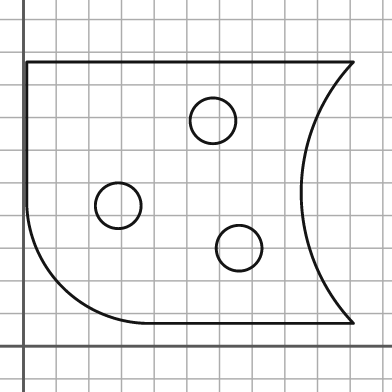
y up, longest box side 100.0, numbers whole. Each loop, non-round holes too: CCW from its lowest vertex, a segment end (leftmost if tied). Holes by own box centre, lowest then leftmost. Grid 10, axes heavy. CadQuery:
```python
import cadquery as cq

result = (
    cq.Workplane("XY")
    .moveTo(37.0, 7.0)
    .lineTo(101.0, 7.0)
    .threePointArc((85.0, 47.0), (101.0, 87.0))
    .lineTo(1.0, 87.0)
    .lineTo(1.0, 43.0)
    .threePointArc((12.0, 18.0), (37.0, 7.0))
    .close()
    .moveTo(66.0, 30.0)
    .circle(7.0)
    .moveTo(29.0, 43.0)
    .circle(7.0)
    .moveTo(58.0, 69.0)
    .circle(7.0)
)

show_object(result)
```